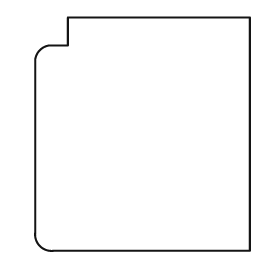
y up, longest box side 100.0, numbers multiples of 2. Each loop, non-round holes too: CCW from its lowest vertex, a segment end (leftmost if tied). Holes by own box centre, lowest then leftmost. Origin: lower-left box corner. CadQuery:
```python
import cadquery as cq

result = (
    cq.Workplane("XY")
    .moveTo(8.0, 0.0)
    .lineTo(92.0, 0.0)
    .lineTo(92.0, 100.0)
    .lineTo(14.0, 100.0)
    .lineTo(14.0, 88.0)
    .lineTo(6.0, 88.0)
    .threePointArc((2.0, 86.0), (0.0, 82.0))
    .lineTo(0.0, 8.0)
    .threePointArc((2.0, 2.0), (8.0, 0.0))
    .close()
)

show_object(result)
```